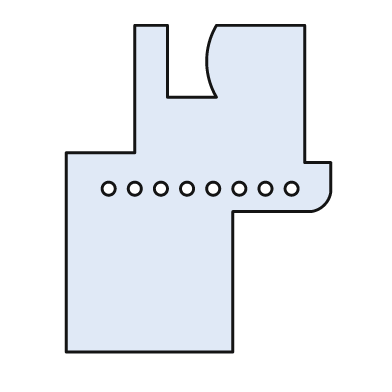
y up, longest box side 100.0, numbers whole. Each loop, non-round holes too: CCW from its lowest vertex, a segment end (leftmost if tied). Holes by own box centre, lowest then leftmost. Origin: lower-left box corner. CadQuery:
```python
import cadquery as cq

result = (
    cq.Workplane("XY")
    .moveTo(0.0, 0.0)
    .lineTo(51.0, 0.0)
    .lineTo(51.0, 43.0)
    .lineTo(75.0, 43.0)
    .threePointArc((79.0, 45.0), (81.0, 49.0))
    .lineTo(81.0, 58.0)
    .lineTo(73.0, 58.0)
    .lineTo(73.0, 100.0)
    .lineTo(46.0, 100.0)
    .threePointArc((43.0, 89.0), (46.0, 78.0))
    .lineTo(31.0, 78.0)
    .lineTo(31.0, 100.0)
    .lineTo(21.0, 100.0)
    .lineTo(21.0, 61.0)
    .lineTo(0.0, 61.0)
    .close()
    .moveTo(13.0, 50.0)
    .circle(2.0)
    .moveTo(21.0, 50.0)
    .circle(2.0)
    .moveTo(29.0, 50.0)
    .circle(2.0)
    .moveTo(37.0, 50.0)
    .circle(2.0)
    .moveTo(45.0, 50.0)
    .circle(2.0)
    .moveTo(53.0, 50.0)
    .circle(2.0)
    .moveTo(61.0, 50.0)
    .circle(2.0)
    .moveTo(69.0, 50.0)
    .circle(2.0)
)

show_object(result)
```